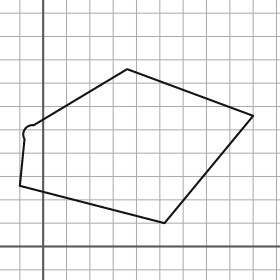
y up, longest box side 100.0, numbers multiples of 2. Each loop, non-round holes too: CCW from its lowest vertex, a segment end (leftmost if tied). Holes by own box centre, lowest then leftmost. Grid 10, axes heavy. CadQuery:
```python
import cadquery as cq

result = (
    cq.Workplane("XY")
    .moveTo(52.0, 10.0)
    .lineTo(90.0, 56.0)
    .lineTo(36.0, 76.0)
    .lineTo(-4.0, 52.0)
    .threePointArc((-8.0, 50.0), (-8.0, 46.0))
    .lineTo(-10.0, 26.0)
    .close()
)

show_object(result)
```